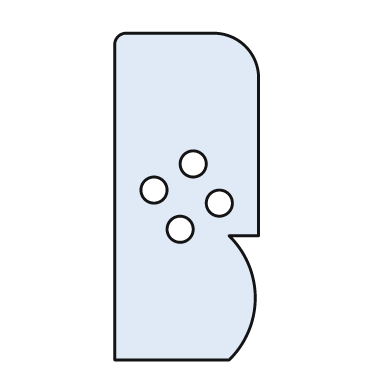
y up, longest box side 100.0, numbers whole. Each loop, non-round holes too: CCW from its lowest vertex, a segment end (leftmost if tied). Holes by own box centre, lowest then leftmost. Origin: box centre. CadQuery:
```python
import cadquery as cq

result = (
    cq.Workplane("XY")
    .moveTo(-22.0, -50.0)
    .lineTo(13.0, -50.0)
    .threePointArc((21.0, -31.0), (13.0, -12.0))
    .lineTo(22.0, -12.0)
    .lineTo(22.0, 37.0)
    .threePointArc((18.0, 46.0), (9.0, 50.0))
    .lineTo(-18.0, 50.0)
    .threePointArc((-21.0, 49.0), (-22.0, 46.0))
    .close()
    .moveTo(-2.0, -10.0)
    .circle(4.0)
    .moveTo(10.0, -2.0)
    .circle(4.0)
    .moveTo(-10.0, 2.0)
    .circle(4.0)
    .moveTo(2.0, 10.0)
    .circle(4.0)
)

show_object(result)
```